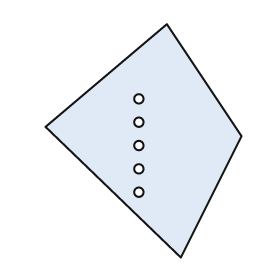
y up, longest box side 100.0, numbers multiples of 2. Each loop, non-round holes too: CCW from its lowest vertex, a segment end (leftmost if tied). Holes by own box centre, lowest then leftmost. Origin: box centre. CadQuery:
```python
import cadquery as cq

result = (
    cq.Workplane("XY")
    .moveTo(16.0, -50.0)
    .lineTo(42.0, 2.0)
    .lineTo(10.0, 50.0)
    .lineTo(-42.0, 6.0)
    .close()
    .moveTo(-2.0, -22.0)
    .circle(2.0)
    .moveTo(-2.0, -12.0)
    .circle(2.0)
    .moveTo(-2.0, -2.0)
    .circle(2.0)
    .moveTo(-2.0, 8.0)
    .circle(2.0)
    .moveTo(-2.0, 18.0)
    .circle(2.0)
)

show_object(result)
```